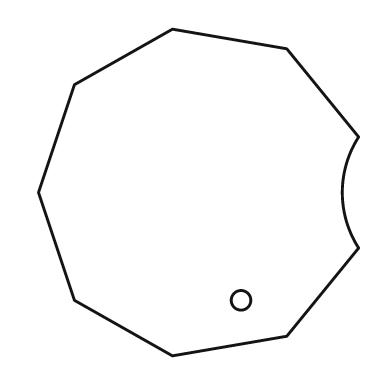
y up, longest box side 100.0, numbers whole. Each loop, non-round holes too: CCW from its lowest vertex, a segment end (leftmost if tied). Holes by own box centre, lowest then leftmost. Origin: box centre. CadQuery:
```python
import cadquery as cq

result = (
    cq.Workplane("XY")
    .moveTo(-8.0, -50.0)
    .lineTo(27.0, -44.0)
    .lineTo(49.0, -17.0)
    .threePointArc((44.0, 0.0), (49.0, 17.0))
    .lineTo(27.0, 44.0)
    .lineTo(-8.0, 50.0)
    .lineTo(-38.0, 33.0)
    .lineTo(-49.0, 0.0)
    .lineTo(-38.0, -33.0)
    .close()
    .moveTo(13.0, -33.0)
    .circle(3.0)
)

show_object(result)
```